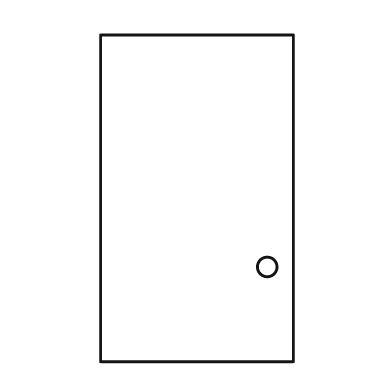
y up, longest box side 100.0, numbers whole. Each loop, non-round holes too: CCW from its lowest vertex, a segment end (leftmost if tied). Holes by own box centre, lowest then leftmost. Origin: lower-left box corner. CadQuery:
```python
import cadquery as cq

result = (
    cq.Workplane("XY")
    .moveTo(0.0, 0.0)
    .lineTo(59.0, 0.0)
    .lineTo(59.0, 100.0)
    .lineTo(0.0, 100.0)
    .close()
    .moveTo(51.0, 29.0)
    .circle(3.0)
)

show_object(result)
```